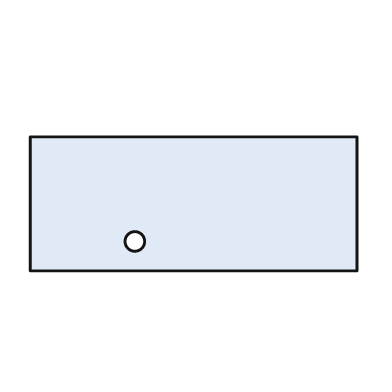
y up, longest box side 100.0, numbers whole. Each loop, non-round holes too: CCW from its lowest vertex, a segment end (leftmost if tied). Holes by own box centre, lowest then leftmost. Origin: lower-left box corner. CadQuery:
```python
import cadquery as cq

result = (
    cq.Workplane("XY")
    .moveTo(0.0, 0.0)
    .lineTo(100.0, 0.0)
    .lineTo(100.0, 41.0)
    .lineTo(0.0, 41.0)
    .close()
    .moveTo(32.0, 9.0)
    .circle(3.0)
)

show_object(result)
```